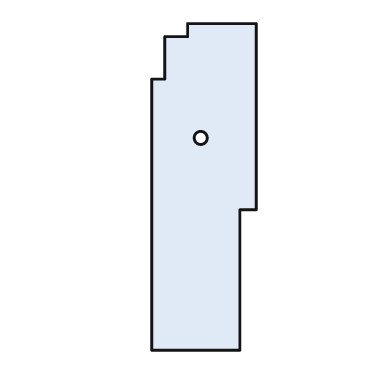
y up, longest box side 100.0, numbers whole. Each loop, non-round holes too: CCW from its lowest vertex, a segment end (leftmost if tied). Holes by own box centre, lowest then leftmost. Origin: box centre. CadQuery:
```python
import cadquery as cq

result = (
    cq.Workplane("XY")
    .moveTo(-16.0, -50.0)
    .lineTo(11.0, -50.0)
    .lineTo(11.0, -7.0)
    .lineTo(16.0, -7.0)
    .lineTo(16.0, 50.0)
    .lineTo(-5.0, 50.0)
    .lineTo(-5.0, 46.0)
    .lineTo(-12.0, 46.0)
    .lineTo(-12.0, 33.0)
    .lineTo(-16.0, 33.0)
    .close()
    .moveTo(-1.0, 15.0)
    .circle(2.0)
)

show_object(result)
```